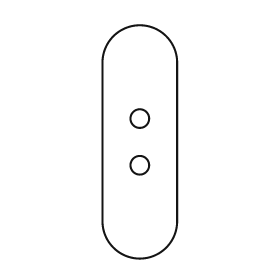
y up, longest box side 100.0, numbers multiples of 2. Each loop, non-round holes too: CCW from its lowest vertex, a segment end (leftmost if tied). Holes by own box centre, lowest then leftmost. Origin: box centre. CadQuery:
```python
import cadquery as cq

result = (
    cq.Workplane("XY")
    .moveTo(-16.0, -34.0)
    .threePointArc((0.0, -50.0), (16.0, -34.0))
    .lineTo(16.0, 34.0)
    .threePointArc((0.0, 50.0), (-16.0, 34.0))
    .close()
    .moveTo(0.0, -10.0)
    .circle(4.0)
    .moveTo(0.0, 10.0)
    .circle(4.0)
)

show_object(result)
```